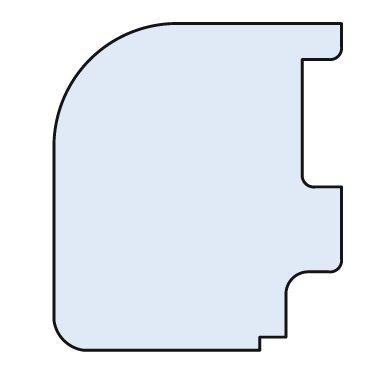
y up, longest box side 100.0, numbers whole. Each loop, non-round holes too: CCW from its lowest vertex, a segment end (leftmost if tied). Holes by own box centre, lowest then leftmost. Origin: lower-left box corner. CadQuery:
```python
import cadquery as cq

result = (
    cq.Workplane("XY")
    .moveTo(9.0, 0.0)
    .lineTo(63.0, 0.0)
    .lineTo(63.0, 4.0)
    .lineTo(71.0, 4.0)
    .lineTo(71.0, 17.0)
    .threePointArc((73.0, 22.0), (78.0, 24.0))
    .lineTo(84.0, 24.0)
    .threePointArc((87.0, 25.0), (88.0, 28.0))
    .lineTo(88.0, 50.0)
    .lineTo(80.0, 50.0)
    .threePointArc((77.0, 51.0), (76.0, 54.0))
    .lineTo(76.0, 89.0)
    .lineTo(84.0, 89.0)
    .threePointArc((87.0, 90.0), (88.0, 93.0))
    .lineTo(88.0, 100.0)
    .lineTo(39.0, 100.0)
    .threePointArc((11.0, 89.0), (0.0, 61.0))
    .lineTo(0.0, 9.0)
    .threePointArc((3.0, 3.0), (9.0, 0.0))
    .close()
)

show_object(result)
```